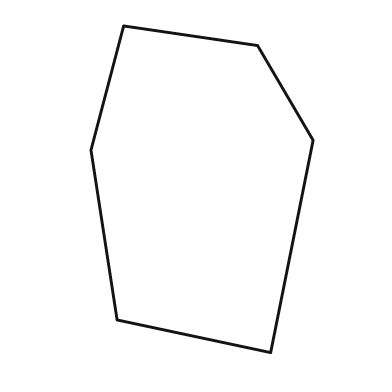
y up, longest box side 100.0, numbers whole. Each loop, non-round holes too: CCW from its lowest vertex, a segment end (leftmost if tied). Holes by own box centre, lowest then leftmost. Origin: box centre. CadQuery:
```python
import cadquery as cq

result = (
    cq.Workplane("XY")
    .moveTo(21.0, -50.0)
    .lineTo(34.0, 15.0)
    .lineTo(17.0, 44.0)
    .lineTo(-24.0, 50.0)
    .lineTo(-34.0, 12.0)
    .lineTo(-26.0, -40.0)
    .close()
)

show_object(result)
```